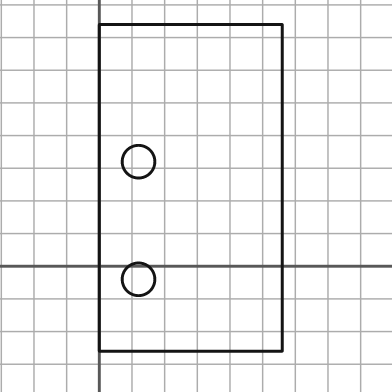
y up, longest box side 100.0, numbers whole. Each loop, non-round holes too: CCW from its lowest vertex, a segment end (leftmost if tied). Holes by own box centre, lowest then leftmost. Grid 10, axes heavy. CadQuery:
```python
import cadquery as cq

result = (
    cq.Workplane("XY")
    .moveTo(0.0, -26.0)
    .lineTo(56.0, -26.0)
    .lineTo(56.0, 74.0)
    .lineTo(0.0, 74.0)
    .close()
    .moveTo(12.0, -4.0)
    .circle(5.0)
    .moveTo(12.0, 32.0)
    .circle(5.0)
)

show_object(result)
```